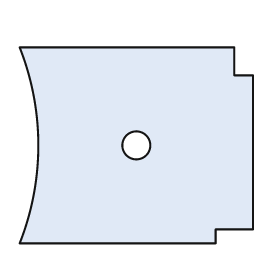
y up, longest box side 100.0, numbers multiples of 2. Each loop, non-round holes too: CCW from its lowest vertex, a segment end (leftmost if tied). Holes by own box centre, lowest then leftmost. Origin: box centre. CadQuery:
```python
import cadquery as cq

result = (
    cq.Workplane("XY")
    .moveTo(-50.0, -42.0)
    .lineTo(34.0, -42.0)
    .lineTo(34.0, -36.0)
    .lineTo(50.0, -36.0)
    .lineTo(50.0, 30.0)
    .lineTo(42.0, 30.0)
    .lineTo(42.0, 42.0)
    .lineTo(-50.0, 42.0)
    .threePointArc((-42.0, 0.0), (-50.0, -42.0))
    .close()
    .moveTo(0.0, 0.0)
    .circle(6.0)
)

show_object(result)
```